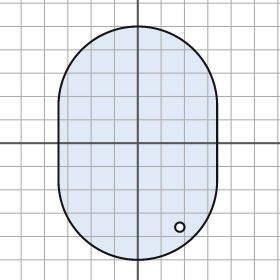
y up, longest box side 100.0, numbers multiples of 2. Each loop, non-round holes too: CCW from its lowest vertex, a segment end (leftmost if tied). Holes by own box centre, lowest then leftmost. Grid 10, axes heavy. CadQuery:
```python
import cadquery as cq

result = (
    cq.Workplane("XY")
    .moveTo(-34.0, -16.0)
    .threePointArc((0.0, -50.0), (34.0, -16.0))
    .lineTo(34.0, 16.0)
    .threePointArc((0.0, 50.0), (-34.0, 16.0))
    .close()
    .moveTo(18.0, -36.0)
    .circle(2.0)
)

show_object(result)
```